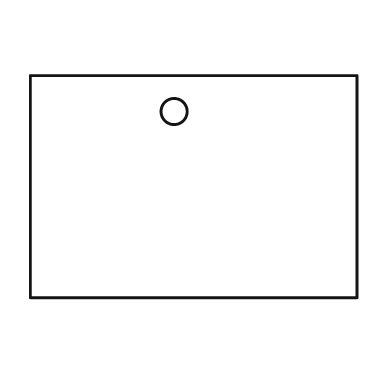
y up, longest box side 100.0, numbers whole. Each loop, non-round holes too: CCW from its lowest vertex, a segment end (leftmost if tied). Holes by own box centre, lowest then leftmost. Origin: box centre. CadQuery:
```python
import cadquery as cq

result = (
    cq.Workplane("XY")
    .moveTo(-50.0, -34.0)
    .lineTo(50.0, -34.0)
    .lineTo(50.0, 34.0)
    .lineTo(-50.0, 34.0)
    .close()
    .moveTo(-6.0, 23.0)
    .circle(4.0)
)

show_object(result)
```